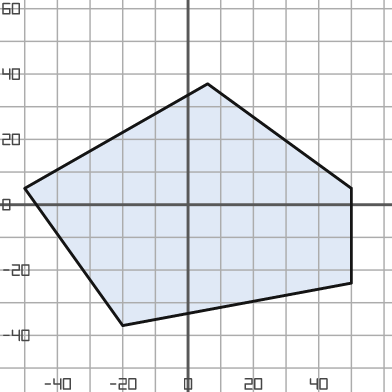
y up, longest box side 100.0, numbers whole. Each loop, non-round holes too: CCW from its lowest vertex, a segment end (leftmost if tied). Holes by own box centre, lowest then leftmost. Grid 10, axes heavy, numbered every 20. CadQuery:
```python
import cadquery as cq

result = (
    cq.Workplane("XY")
    .moveTo(-20.0, -37.0)
    .lineTo(50.0, -24.0)
    .lineTo(50.0, 5.0)
    .lineTo(6.0, 37.0)
    .lineTo(-50.0, 5.0)
    .close()
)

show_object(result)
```